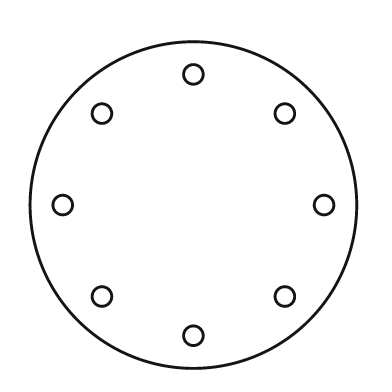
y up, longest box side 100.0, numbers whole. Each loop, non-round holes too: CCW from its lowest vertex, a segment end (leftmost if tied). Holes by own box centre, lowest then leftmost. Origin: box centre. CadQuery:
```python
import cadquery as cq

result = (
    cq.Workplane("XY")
    .moveTo(0.0, 0.0)
    .circle(50.0)
    .moveTo(0.0, -40.0)
    .circle(3.0)
    .moveTo(-28.0, -28.0)
    .circle(3.0)
    .moveTo(28.0, -28.0)
    .circle(3.0)
    .moveTo(-40.0, 0.0)
    .circle(3.0)
    .moveTo(40.0, 0.0)
    .circle(3.0)
    .moveTo(-28.0, 28.0)
    .circle(3.0)
    .moveTo(28.0, 28.0)
    .circle(3.0)
    .moveTo(0.0, 40.0)
    .circle(3.0)
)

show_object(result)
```